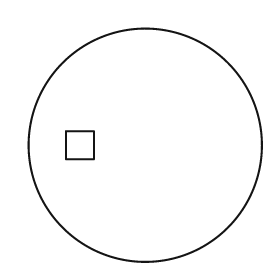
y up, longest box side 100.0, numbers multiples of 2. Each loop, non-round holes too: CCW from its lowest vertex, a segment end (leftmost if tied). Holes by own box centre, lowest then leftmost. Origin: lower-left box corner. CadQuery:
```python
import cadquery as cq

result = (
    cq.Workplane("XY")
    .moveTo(50.0, 50.0)
    .circle(50.0)
    .moveTo(16.0, 44.0)
    .lineTo(28.0, 44.0)
    .lineTo(28.0, 56.0)
    .lineTo(16.0, 56.0)
    .close()
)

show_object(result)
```